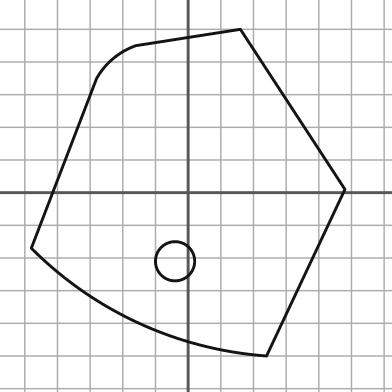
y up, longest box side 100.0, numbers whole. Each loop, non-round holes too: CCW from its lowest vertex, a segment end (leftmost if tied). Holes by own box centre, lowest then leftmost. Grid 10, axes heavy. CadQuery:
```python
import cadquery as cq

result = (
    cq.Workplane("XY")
    .moveTo(24.0, -50.0)
    .lineTo(48.0, 1.0)
    .lineTo(16.0, 50.0)
    .lineTo(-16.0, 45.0)
    .threePointArc((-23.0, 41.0), (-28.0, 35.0))
    .lineTo(-48.0, -17.0)
    .threePointArc((-15.0, -40.0), (24.0, -50.0))
    .close()
    .moveTo(-4.0, -21.0)
    .circle(6.0)
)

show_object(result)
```